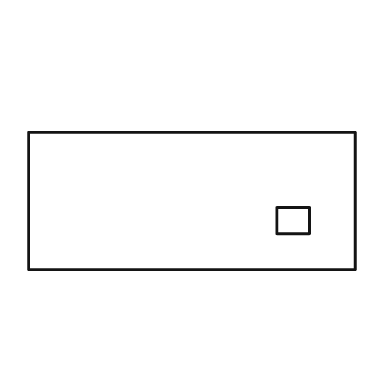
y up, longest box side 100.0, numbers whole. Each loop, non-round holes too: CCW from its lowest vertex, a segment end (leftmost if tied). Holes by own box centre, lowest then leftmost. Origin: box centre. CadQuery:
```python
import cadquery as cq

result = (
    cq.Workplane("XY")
    .moveTo(-50.0, -21.0)
    .lineTo(50.0, -21.0)
    .lineTo(50.0, 21.0)
    .lineTo(-50.0, 21.0)
    .close()
    .moveTo(26.0, -10.0)
    .lineTo(36.0, -10.0)
    .lineTo(36.0, -2.0)
    .lineTo(26.0, -2.0)
    .close()
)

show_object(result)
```